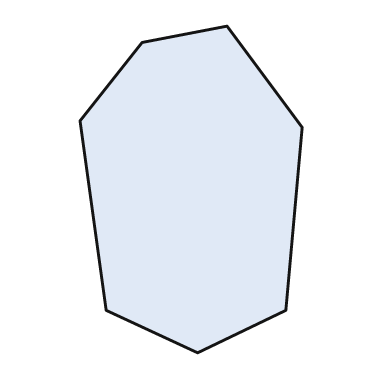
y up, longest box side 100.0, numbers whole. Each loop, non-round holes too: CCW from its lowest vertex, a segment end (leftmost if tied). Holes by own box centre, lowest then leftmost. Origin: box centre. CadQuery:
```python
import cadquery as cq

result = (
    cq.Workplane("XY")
    .moveTo(2.0, -50.0)
    .lineTo(29.0, -37.0)
    .lineTo(34.0, 19.0)
    .lineTo(11.0, 50.0)
    .lineTo(-15.0, 45.0)
    .lineTo(-34.0, 21.0)
    .lineTo(-26.0, -37.0)
    .close()
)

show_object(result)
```